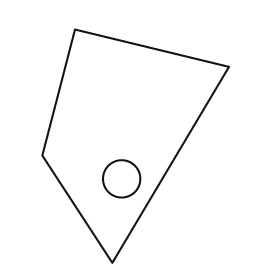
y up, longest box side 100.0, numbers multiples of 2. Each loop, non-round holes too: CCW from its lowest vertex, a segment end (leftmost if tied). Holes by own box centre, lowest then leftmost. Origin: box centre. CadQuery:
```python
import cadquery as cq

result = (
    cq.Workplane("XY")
    .moveTo(-10.0, -50.0)
    .lineTo(40.0, 34.0)
    .lineTo(-26.0, 50.0)
    .lineTo(-40.0, -4.0)
    .close()
    .moveTo(-6.0, -14.0)
    .circle(8.0)
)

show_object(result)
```